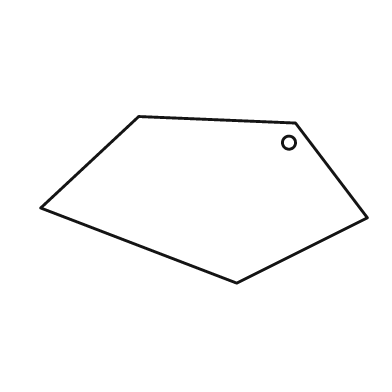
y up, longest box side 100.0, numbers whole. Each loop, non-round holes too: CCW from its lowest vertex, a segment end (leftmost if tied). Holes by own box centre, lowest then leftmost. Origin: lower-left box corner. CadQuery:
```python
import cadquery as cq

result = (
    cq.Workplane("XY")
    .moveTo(60.0, 0.0)
    .lineTo(100.0, 20.0)
    .lineTo(78.0, 49.0)
    .lineTo(30.0, 51.0)
    .lineTo(0.0, 23.0)
    .close()
    .moveTo(76.0, 43.0)
    .circle(2.0)
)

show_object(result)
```